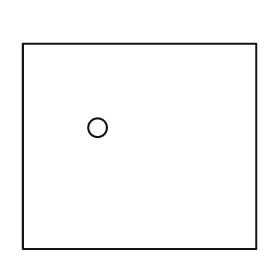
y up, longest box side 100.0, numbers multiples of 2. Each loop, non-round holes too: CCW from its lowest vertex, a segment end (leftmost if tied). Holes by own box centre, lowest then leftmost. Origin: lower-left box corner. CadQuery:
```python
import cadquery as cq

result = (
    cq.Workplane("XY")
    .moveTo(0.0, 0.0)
    .lineTo(100.0, 0.0)
    .lineTo(100.0, 88.0)
    .lineTo(0.0, 88.0)
    .close()
    .moveTo(32.0, 52.0)
    .circle(4.0)
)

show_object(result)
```